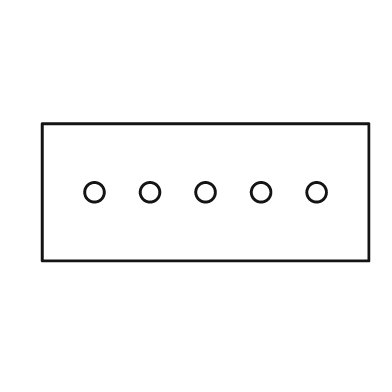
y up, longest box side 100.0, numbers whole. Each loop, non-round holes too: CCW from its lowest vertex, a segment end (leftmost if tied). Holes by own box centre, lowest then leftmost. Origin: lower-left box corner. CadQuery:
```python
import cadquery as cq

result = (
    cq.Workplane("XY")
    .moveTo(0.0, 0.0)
    .lineTo(100.0, 0.0)
    .lineTo(100.0, 42.0)
    .lineTo(0.0, 42.0)
    .close()
    .moveTo(16.0, 21.0)
    .circle(3.0)
    .moveTo(33.0, 21.0)
    .circle(3.0)
    .moveTo(50.0, 21.0)
    .circle(3.0)
    .moveTo(67.0, 21.0)
    .circle(3.0)
    .moveTo(84.0, 21.0)
    .circle(3.0)
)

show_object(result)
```